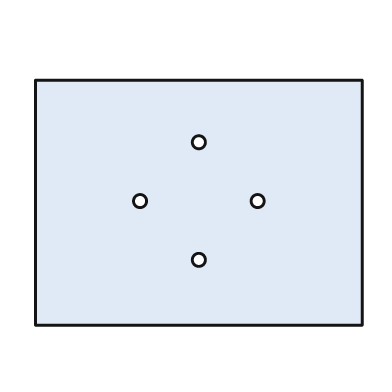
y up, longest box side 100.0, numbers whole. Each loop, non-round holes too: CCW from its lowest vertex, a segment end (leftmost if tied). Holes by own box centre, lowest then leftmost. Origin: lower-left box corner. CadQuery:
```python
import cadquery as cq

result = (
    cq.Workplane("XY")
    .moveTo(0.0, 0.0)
    .lineTo(100.0, 0.0)
    .lineTo(100.0, 75.0)
    .lineTo(0.0, 75.0)
    .close()
    .moveTo(50.0, 20.0)
    .circle(2.0)
    .moveTo(32.0, 38.0)
    .circle(2.0)
    .moveTo(68.0, 38.0)
    .circle(2.0)
    .moveTo(50.0, 56.0)
    .circle(2.0)
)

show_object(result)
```